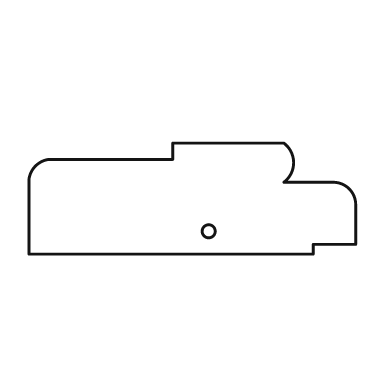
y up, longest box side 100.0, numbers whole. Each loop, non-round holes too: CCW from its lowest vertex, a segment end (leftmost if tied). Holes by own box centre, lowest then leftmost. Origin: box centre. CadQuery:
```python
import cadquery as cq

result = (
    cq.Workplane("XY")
    .moveTo(-50.0, -17.0)
    .lineTo(37.0, -17.0)
    .lineTo(37.0, -14.0)
    .lineTo(50.0, -14.0)
    .lineTo(50.0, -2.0)
    .threePointArc((48.0, 3.0), (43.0, 5.0))
    .lineTo(28.0, 5.0)
    .threePointArc((31.0, 11.0), (28.0, 17.0))
    .lineTo(-6.0, 17.0)
    .lineTo(-6.0, 12.0)
    .lineTo(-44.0, 12.0)
    .threePointArc((-48.0, 10.0), (-50.0, 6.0))
    .close()
    .moveTo(5.0, -10.0)
    .circle(2.0)
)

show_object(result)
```